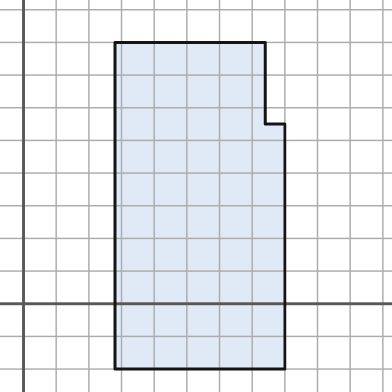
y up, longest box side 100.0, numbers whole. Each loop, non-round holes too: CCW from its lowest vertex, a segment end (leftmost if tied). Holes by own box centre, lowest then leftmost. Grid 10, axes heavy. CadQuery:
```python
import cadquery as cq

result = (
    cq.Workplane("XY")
    .moveTo(28.0, -20.0)
    .lineTo(80.0, -20.0)
    .lineTo(80.0, 55.0)
    .lineTo(74.0, 55.0)
    .lineTo(74.0, 80.0)
    .lineTo(28.0, 80.0)
    .close()
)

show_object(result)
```